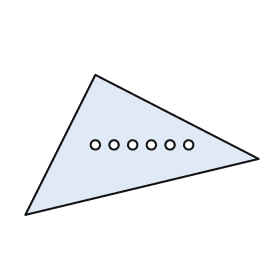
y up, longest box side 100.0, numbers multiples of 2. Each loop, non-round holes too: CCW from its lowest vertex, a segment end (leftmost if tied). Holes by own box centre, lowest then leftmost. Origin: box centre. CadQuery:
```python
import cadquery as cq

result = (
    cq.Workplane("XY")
    .moveTo(-50.0, -30.0)
    .lineTo(50.0, -6.0)
    .lineTo(-20.0, 30.0)
    .close()
    .moveTo(-20.0, 0.0)
    .circle(2.0)
    .moveTo(-12.0, 0.0)
    .circle(2.0)
    .moveTo(-4.0, 0.0)
    .circle(2.0)
    .moveTo(4.0, 0.0)
    .circle(2.0)
    .moveTo(12.0, 0.0)
    .circle(2.0)
    .moveTo(20.0, 0.0)
    .circle(2.0)
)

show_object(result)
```